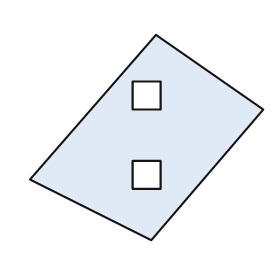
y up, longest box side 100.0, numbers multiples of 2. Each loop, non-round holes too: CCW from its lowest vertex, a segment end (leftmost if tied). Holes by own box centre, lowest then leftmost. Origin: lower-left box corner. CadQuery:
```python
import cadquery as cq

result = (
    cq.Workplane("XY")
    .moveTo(52.0, 0.0)
    .lineTo(100.0, 56.0)
    .lineTo(54.0, 88.0)
    .lineTo(0.0, 26.0)
    .close()
    .moveTo(44.0, 22.0)
    .lineTo(56.0, 22.0)
    .lineTo(56.0, 34.0)
    .lineTo(44.0, 34.0)
    .close()
    .moveTo(44.0, 56.0)
    .lineTo(56.0, 56.0)
    .lineTo(56.0, 68.0)
    .lineTo(44.0, 68.0)
    .close()
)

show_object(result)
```